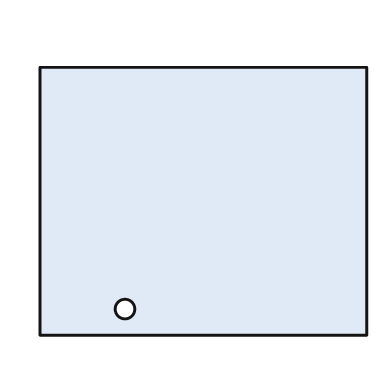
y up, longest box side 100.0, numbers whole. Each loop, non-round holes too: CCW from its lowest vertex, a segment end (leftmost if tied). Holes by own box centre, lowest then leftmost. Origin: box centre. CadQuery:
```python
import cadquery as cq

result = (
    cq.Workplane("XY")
    .moveTo(-50.0, -41.0)
    .lineTo(50.0, -41.0)
    .lineTo(50.0, 41.0)
    .lineTo(-50.0, 41.0)
    .close()
    .moveTo(-24.0, -33.0)
    .circle(3.0)
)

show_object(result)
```